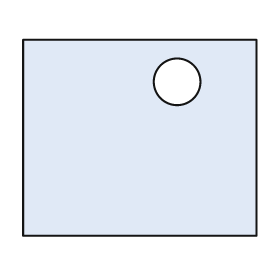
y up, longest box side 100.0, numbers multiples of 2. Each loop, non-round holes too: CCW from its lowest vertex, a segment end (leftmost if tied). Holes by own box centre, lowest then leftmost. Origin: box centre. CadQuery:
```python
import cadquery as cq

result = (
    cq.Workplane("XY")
    .moveTo(-50.0, -42.0)
    .lineTo(50.0, -42.0)
    .lineTo(50.0, 42.0)
    .lineTo(-50.0, 42.0)
    .close()
    .moveTo(16.0, 24.0)
    .circle(10.0)
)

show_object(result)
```